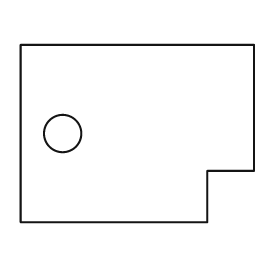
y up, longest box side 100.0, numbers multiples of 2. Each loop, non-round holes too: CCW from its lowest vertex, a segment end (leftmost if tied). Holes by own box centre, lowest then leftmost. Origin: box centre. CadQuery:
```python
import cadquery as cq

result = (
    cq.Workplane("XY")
    .moveTo(-50.0, -38.0)
    .lineTo(30.0, -38.0)
    .lineTo(30.0, -16.0)
    .lineTo(50.0, -16.0)
    .lineTo(50.0, 38.0)
    .lineTo(-50.0, 38.0)
    .close()
    .moveTo(-32.0, 0.0)
    .circle(8.0)
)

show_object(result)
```